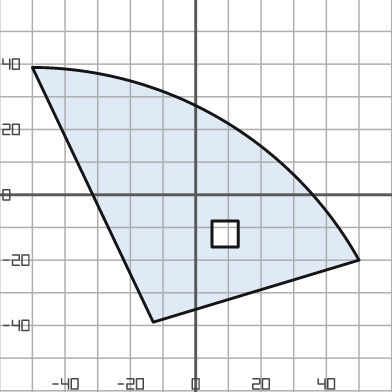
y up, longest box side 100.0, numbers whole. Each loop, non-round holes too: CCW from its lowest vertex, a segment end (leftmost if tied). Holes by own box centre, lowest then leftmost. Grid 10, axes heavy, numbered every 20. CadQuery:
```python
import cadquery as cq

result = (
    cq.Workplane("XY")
    .moveTo(-13.0, -39.0)
    .lineTo(50.0, -20.0)
    .threePointArc((8.0, 23.0), (-50.0, 39.0))
    .close()
    .moveTo(5.0, -16.0)
    .lineTo(13.0, -16.0)
    .lineTo(13.0, -8.0)
    .lineTo(5.0, -8.0)
    .close()
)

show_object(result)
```